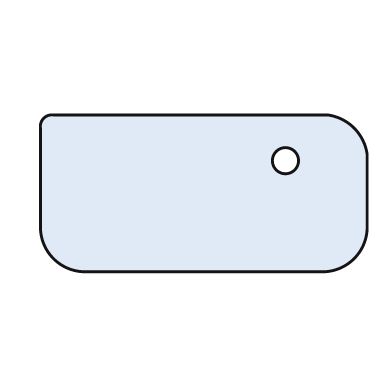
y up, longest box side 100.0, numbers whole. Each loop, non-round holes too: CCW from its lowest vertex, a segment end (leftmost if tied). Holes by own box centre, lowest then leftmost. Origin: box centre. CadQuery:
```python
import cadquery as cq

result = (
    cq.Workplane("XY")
    .moveTo(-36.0, -24.0)
    .lineTo(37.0, -24.0)
    .threePointArc((46.0, -20.0), (50.0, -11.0))
    .lineTo(50.0, 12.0)
    .threePointArc((46.0, 20.0), (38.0, 24.0))
    .lineTo(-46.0, 24.0)
    .threePointArc((-49.0, 23.0), (-50.0, 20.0))
    .lineTo(-50.0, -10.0)
    .threePointArc((-46.0, -20.0), (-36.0, -24.0))
    .close()
    .moveTo(25.0, 10.0)
    .circle(4.0)
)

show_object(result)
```